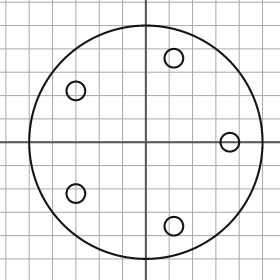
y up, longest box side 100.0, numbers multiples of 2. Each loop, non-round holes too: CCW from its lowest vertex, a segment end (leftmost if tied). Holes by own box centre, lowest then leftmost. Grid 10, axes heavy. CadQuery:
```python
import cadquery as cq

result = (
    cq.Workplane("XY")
    .moveTo(0.0, 0.0)
    .circle(50.0)
    .moveTo(12.0, -36.0)
    .circle(4.0)
    .moveTo(-30.0, -22.0)
    .circle(4.0)
    .moveTo(36.0, 0.0)
    .circle(4.0)
    .moveTo(-30.0, 22.0)
    .circle(4.0)
    .moveTo(12.0, 36.0)
    .circle(4.0)
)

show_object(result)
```